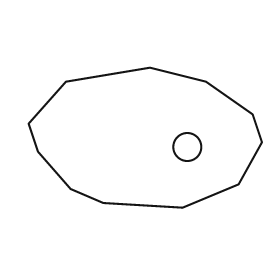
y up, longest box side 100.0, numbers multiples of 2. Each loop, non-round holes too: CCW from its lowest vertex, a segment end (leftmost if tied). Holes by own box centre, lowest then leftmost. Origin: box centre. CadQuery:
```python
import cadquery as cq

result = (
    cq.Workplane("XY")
    .moveTo(16.0, -30.0)
    .lineTo(40.0, -20.0)
    .lineTo(50.0, -2.0)
    .lineTo(46.0, 10.0)
    .lineTo(26.0, 24.0)
    .lineTo(2.0, 30.0)
    .lineTo(-34.0, 24.0)
    .lineTo(-50.0, 6.0)
    .lineTo(-46.0, -6.0)
    .lineTo(-32.0, -22.0)
    .lineTo(-18.0, -28.0)
    .close()
    .moveTo(18.0, -4.0)
    .circle(6.0)
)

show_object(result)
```